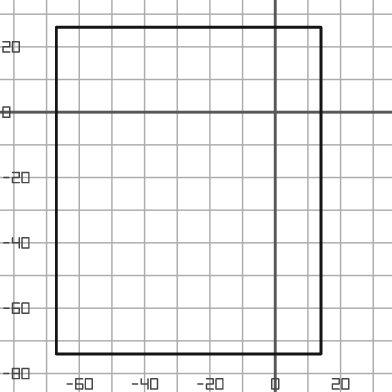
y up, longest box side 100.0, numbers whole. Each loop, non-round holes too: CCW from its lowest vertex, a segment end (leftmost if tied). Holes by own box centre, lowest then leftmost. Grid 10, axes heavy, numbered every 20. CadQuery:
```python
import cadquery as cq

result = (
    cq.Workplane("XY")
    .moveTo(-67.0, -74.0)
    .lineTo(14.0, -74.0)
    .lineTo(14.0, 26.0)
    .lineTo(-67.0, 26.0)
    .close()
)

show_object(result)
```